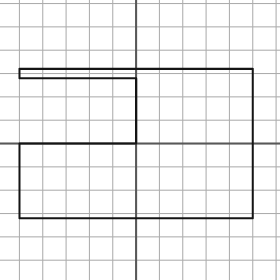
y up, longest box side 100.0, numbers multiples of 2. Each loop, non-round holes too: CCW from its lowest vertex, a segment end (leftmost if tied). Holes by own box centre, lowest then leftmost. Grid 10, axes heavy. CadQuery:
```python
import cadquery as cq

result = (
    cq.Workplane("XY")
    .moveTo(-50.0, -32.0)
    .lineTo(50.0, -32.0)
    .lineTo(50.0, 32.0)
    .lineTo(-50.0, 32.0)
    .lineTo(-50.0, 28.0)
    .lineTo(0.0, 28.0)
    .lineTo(0.0, 0.0)
    .lineTo(-50.0, 0.0)
    .close()
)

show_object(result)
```